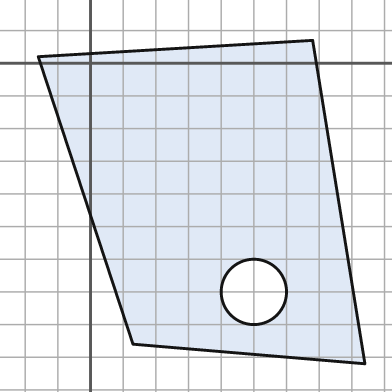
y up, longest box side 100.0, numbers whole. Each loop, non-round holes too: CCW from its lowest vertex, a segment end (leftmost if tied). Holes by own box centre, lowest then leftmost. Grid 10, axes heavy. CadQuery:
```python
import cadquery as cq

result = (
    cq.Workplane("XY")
    .moveTo(84.0, -92.0)
    .lineTo(68.0, 7.0)
    .lineTo(-16.0, 2.0)
    .lineTo(13.0, -86.0)
    .close()
    .moveTo(50.0, -70.0)
    .circle(10.0)
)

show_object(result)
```